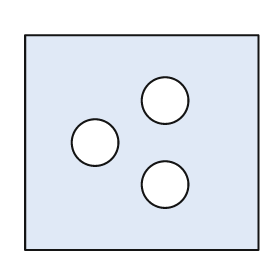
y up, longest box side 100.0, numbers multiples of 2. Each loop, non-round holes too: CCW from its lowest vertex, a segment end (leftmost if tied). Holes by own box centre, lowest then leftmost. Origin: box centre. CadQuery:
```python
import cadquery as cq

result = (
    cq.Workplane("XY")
    .moveTo(-50.0, -46.0)
    .lineTo(50.0, -46.0)
    .lineTo(50.0, 46.0)
    .lineTo(-50.0, 46.0)
    .close()
    .moveTo(10.0, -18.0)
    .circle(10.0)
    .moveTo(-20.0, 0.0)
    .circle(10.0)
    .moveTo(10.0, 18.0)
    .circle(10.0)
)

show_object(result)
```